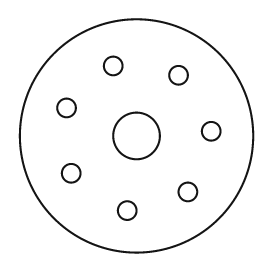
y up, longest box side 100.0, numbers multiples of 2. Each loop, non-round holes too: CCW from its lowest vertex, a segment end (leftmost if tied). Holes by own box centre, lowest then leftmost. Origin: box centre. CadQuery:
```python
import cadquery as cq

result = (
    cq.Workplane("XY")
    .moveTo(0.0, 0.0)
    .circle(50.0)
    .moveTo(-4.0, -32.0)
    .circle(4.0)
    .moveTo(22.0, -24.0)
    .circle(4.0)
    .moveTo(-28.0, -16.0)
    .circle(4.0)
    .moveTo(0.0, 0.0)
    .circle(10.0)
    .moveTo(32.0, 2.0)
    .circle(4.0)
    .moveTo(-30.0, 12.0)
    .circle(4.0)
    .moveTo(18.0, 26.0)
    .circle(4.0)
    .moveTo(-10.0, 30.0)
    .circle(4.0)
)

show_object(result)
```